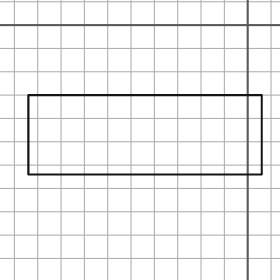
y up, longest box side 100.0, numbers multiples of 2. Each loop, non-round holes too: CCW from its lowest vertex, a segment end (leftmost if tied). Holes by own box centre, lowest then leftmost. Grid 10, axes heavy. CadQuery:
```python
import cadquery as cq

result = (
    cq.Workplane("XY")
    .moveTo(-94.0, -64.0)
    .lineTo(6.0, -64.0)
    .lineTo(6.0, -30.0)
    .lineTo(-94.0, -30.0)
    .close()
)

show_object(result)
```